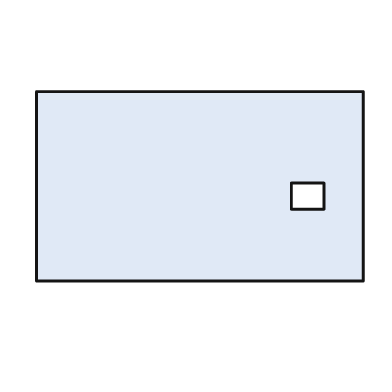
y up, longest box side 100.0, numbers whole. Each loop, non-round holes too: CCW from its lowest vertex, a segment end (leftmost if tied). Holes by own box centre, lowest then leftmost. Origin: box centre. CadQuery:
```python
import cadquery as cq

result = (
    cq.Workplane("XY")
    .moveTo(-50.0, -29.0)
    .lineTo(50.0, -29.0)
    .lineTo(50.0, 29.0)
    .lineTo(-50.0, 29.0)
    .close()
    .moveTo(28.0, -7.0)
    .lineTo(38.0, -7.0)
    .lineTo(38.0, 1.0)
    .lineTo(28.0, 1.0)
    .close()
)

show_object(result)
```